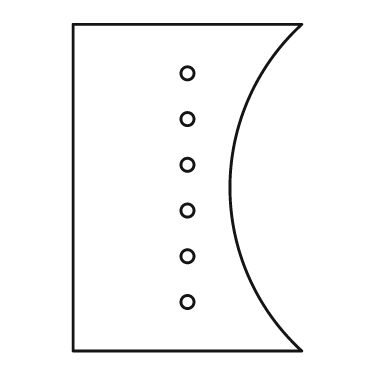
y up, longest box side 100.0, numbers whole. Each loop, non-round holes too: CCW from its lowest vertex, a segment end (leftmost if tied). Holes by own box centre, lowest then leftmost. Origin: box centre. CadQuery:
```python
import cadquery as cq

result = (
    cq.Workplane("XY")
    .moveTo(-35.0, -50.0)
    .lineTo(35.0, -50.0)
    .threePointArc((13.0, 0.0), (35.0, 50.0))
    .lineTo(-35.0, 50.0)
    .close()
    .moveTo(0.0, -35.0)
    .circle(2.0)
    .moveTo(0.0, -21.0)
    .circle(2.0)
    .moveTo(0.0, -7.0)
    .circle(2.0)
    .moveTo(0.0, 7.0)
    .circle(2.0)
    .moveTo(0.0, 21.0)
    .circle(2.0)
    .moveTo(0.0, 35.0)
    .circle(2.0)
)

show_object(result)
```